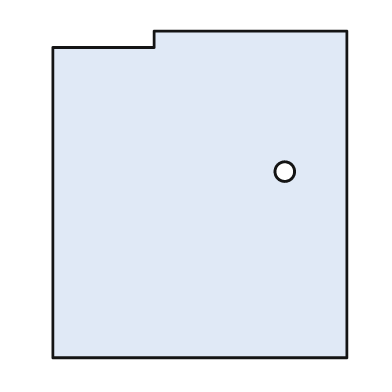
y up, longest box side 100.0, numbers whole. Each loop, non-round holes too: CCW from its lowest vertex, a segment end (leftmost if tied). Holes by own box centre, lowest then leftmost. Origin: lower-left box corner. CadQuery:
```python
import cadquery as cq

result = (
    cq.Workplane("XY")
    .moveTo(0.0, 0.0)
    .lineTo(90.0, 0.0)
    .lineTo(90.0, 100.0)
    .lineTo(31.0, 100.0)
    .lineTo(31.0, 95.0)
    .lineTo(0.0, 95.0)
    .close()
    .moveTo(71.0, 57.0)
    .circle(3.0)
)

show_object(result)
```